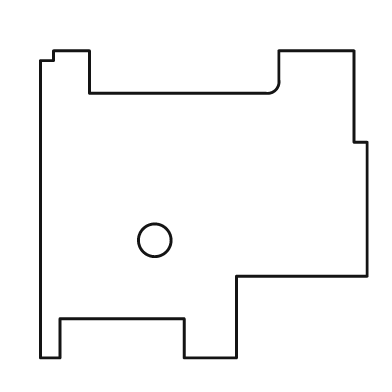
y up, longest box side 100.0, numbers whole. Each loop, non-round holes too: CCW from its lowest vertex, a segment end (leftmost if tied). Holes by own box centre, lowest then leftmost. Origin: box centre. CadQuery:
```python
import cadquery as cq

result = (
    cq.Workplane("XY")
    .moveTo(-50.0, -47.0)
    .lineTo(-44.0, -47.0)
    .lineTo(-44.0, -35.0)
    .lineTo(-6.0, -35.0)
    .lineTo(-6.0, -47.0)
    .lineTo(10.0, -47.0)
    .lineTo(10.0, -22.0)
    .lineTo(50.0, -22.0)
    .lineTo(50.0, 19.0)
    .lineTo(46.0, 19.0)
    .lineTo(46.0, 47.0)
    .lineTo(23.0, 47.0)
    .lineTo(23.0, 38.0)
    .threePointArc((22.0, 35.0), (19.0, 34.0))
    .lineTo(-35.0, 34.0)
    .lineTo(-35.0, 47.0)
    .lineTo(-46.0, 47.0)
    .lineTo(-46.0, 44.0)
    .lineTo(-50.0, 44.0)
    .close()
    .moveTo(-15.0, -11.0)
    .circle(5.0)
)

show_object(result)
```